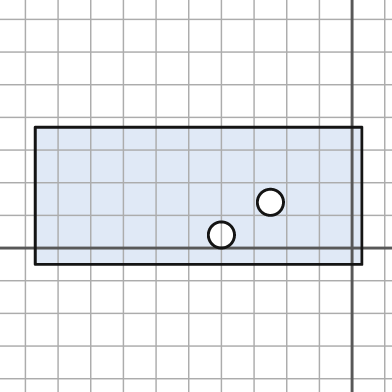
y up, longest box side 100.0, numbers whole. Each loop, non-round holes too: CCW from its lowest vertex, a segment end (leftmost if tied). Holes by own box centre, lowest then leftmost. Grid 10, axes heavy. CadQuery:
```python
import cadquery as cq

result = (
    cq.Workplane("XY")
    .moveTo(-97.0, -5.0)
    .lineTo(3.0, -5.0)
    .lineTo(3.0, 37.0)
    .lineTo(-97.0, 37.0)
    .close()
    .moveTo(-40.0, 4.0)
    .circle(4.0)
    .moveTo(-25.0, 14.0)
    .circle(4.0)
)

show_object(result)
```